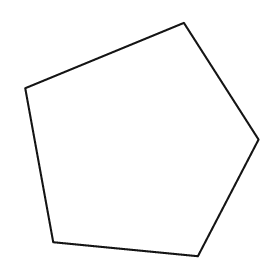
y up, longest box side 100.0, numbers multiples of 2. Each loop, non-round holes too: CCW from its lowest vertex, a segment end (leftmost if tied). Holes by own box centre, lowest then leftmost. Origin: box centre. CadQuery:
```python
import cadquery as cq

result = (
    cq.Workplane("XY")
    .moveTo(24.0, -50.0)
    .lineTo(50.0, 0.0)
    .lineTo(18.0, 50.0)
    .lineTo(-50.0, 22.0)
    .lineTo(-38.0, -44.0)
    .close()
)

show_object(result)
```